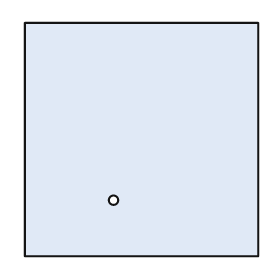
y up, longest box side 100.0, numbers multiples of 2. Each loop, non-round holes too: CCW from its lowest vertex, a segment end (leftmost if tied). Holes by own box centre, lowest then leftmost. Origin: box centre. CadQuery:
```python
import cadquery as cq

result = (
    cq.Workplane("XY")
    .moveTo(-50.0, -50.0)
    .lineTo(50.0, -50.0)
    .lineTo(50.0, 50.0)
    .lineTo(-50.0, 50.0)
    .close()
    .moveTo(-12.0, -26.0)
    .circle(2.0)
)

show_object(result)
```